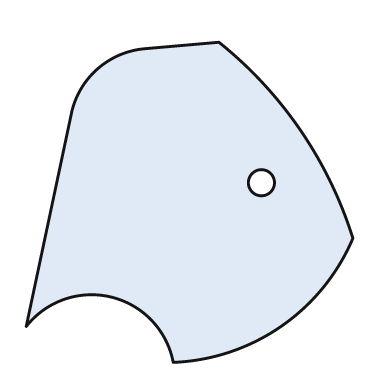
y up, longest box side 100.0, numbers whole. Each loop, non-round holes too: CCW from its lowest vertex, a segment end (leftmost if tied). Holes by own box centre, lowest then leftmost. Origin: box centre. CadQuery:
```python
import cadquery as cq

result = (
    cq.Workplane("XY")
    .moveTo(-5.0, -49.0)
    .threePointArc((28.0, -38.0), (50.0, -11.0))
    .threePointArc((34.0, 22.0), (9.0, 49.0))
    .lineTo(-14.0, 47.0)
    .threePointArc((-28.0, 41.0), (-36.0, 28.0))
    .lineTo(-50.0, -38.0)
    .threePointArc((-24.0, -29.0), (-5.0, -49.0))
    .close()
    .moveTo(22.0, 6.0)
    .circle(4.0)
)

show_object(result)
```